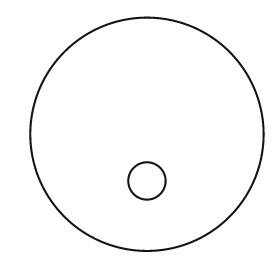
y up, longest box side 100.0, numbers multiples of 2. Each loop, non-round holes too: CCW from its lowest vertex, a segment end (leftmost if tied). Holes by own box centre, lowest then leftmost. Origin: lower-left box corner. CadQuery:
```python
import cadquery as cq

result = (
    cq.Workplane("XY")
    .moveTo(50.0, 50.0)
    .circle(50.0)
    .moveTo(50.0, 30.0)
    .circle(8.0)
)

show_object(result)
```